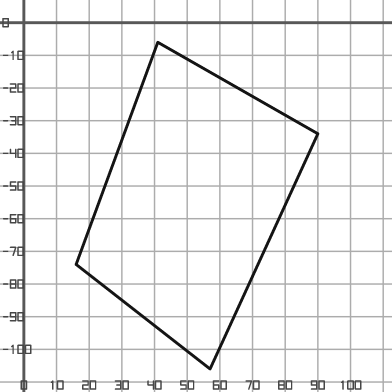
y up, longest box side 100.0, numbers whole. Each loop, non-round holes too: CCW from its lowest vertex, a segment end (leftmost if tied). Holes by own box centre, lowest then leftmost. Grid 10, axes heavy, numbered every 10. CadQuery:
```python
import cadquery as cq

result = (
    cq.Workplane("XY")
    .moveTo(57.0, -106.0)
    .lineTo(90.0, -34.0)
    .lineTo(41.0, -6.0)
    .lineTo(16.0, -74.0)
    .close()
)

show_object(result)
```